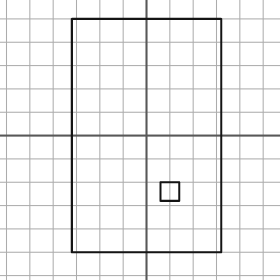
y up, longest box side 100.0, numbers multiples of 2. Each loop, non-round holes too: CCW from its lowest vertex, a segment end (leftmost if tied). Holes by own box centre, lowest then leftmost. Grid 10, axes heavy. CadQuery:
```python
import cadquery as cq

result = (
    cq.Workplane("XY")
    .moveTo(-32.0, -50.0)
    .lineTo(32.0, -50.0)
    .lineTo(32.0, 50.0)
    .lineTo(-32.0, 50.0)
    .close()
    .moveTo(6.0, -28.0)
    .lineTo(14.0, -28.0)
    .lineTo(14.0, -20.0)
    .lineTo(6.0, -20.0)
    .close()
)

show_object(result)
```